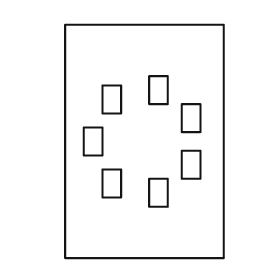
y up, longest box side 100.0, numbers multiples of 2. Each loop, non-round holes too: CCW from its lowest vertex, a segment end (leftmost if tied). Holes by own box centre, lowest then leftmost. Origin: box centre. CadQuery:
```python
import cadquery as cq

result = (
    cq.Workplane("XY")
    .moveTo(-34.0, -50.0)
    .lineTo(34.0, -50.0)
    .lineTo(34.0, 50.0)
    .lineTo(-34.0, 50.0)
    .close()
    .moveTo(2.0, -28.0)
    .lineTo(10.0, -28.0)
    .lineTo(10.0, -16.0)
    .lineTo(2.0, -16.0)
    .close()
    .moveTo(-18.0, -24.0)
    .lineTo(-10.0, -24.0)
    .lineTo(-10.0, -12.0)
    .lineTo(-18.0, -12.0)
    .close()
    .moveTo(16.0, -16.0)
    .lineTo(24.0, -16.0)
    .lineTo(24.0, -4.0)
    .lineTo(16.0, -4.0)
    .close()
    .moveTo(-26.0, -6.0)
    .lineTo(-18.0, -6.0)
    .lineTo(-18.0, 6.0)
    .lineTo(-26.0, 6.0)
    .close()
    .moveTo(16.0, 4.0)
    .lineTo(24.0, 4.0)
    .lineTo(24.0, 16.0)
    .lineTo(16.0, 16.0)
    .close()
    .moveTo(-18.0, 12.0)
    .lineTo(-10.0, 12.0)
    .lineTo(-10.0, 24.0)
    .lineTo(-18.0, 24.0)
    .close()
    .moveTo(2.0, 16.0)
    .lineTo(10.0, 16.0)
    .lineTo(10.0, 28.0)
    .lineTo(2.0, 28.0)
    .close()
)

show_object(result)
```